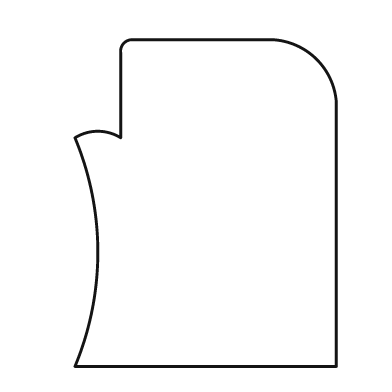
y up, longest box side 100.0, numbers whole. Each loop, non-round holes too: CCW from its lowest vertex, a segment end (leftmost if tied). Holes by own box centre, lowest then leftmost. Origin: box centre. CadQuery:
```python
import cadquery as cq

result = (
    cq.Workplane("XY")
    .moveTo(-40.0, -50.0)
    .lineTo(40.0, -50.0)
    .lineTo(40.0, 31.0)
    .threePointArc((34.0, 44.0), (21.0, 50.0))
    .lineTo(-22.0, 50.0)
    .threePointArc((-25.0, 49.0), (-26.0, 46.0))
    .lineTo(-26.0, 20.0)
    .threePointArc((-33.0, 22.0), (-40.0, 20.0))
    .threePointArc((-33.0, -15.0), (-40.0, -50.0))
    .close()
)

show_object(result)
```